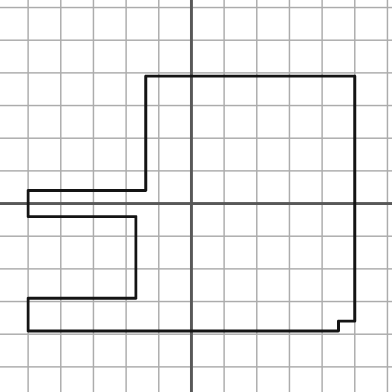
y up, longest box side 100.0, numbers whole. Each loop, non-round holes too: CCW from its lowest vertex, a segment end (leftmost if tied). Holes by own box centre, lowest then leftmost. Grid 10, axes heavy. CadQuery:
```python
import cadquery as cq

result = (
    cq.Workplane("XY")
    .moveTo(-50.0, -39.0)
    .lineTo(45.0, -39.0)
    .lineTo(45.0, -36.0)
    .lineTo(50.0, -36.0)
    .lineTo(50.0, 39.0)
    .lineTo(-14.0, 39.0)
    .lineTo(-14.0, 4.0)
    .lineTo(-50.0, 4.0)
    .lineTo(-50.0, -4.0)
    .lineTo(-17.0, -4.0)
    .lineTo(-17.0, -29.0)
    .lineTo(-50.0, -29.0)
    .close()
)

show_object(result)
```